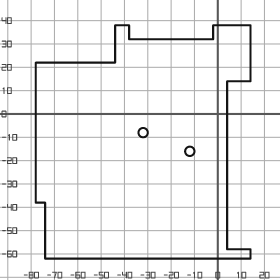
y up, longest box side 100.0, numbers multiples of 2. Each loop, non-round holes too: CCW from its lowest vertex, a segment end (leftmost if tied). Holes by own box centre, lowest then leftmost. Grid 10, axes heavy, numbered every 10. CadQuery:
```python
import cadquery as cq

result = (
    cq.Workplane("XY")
    .moveTo(-74.0, -62.0)
    .lineTo(14.0, -62.0)
    .lineTo(14.0, -58.0)
    .lineTo(4.0, -58.0)
    .lineTo(4.0, 14.0)
    .lineTo(14.0, 14.0)
    .lineTo(14.0, 38.0)
    .lineTo(-2.0, 38.0)
    .lineTo(-2.0, 32.0)
    .lineTo(-38.0, 32.0)
    .lineTo(-38.0, 38.0)
    .lineTo(-44.0, 38.0)
    .lineTo(-44.0, 22.0)
    .lineTo(-78.0, 22.0)
    .lineTo(-78.0, -38.0)
    .lineTo(-74.0, -38.0)
    .close()
    .moveTo(-12.0, -16.0)
    .circle(2.0)
    .moveTo(-32.0, -8.0)
    .circle(2.0)
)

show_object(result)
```